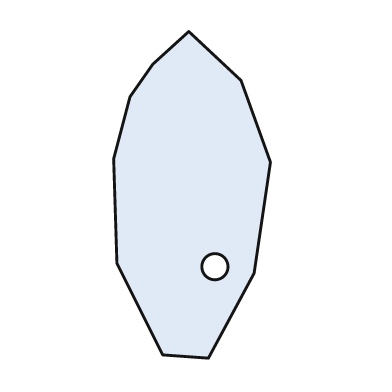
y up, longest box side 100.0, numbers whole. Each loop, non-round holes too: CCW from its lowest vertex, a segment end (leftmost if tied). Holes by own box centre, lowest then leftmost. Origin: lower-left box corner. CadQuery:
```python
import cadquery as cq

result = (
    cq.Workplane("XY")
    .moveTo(29.0, 0.0)
    .lineTo(43.0, 26.0)
    .lineTo(48.0, 60.0)
    .lineTo(39.0, 85.0)
    .lineTo(23.0, 100.0)
    .lineTo(12.0, 90.0)
    .lineTo(5.0, 80.0)
    .lineTo(0.0, 61.0)
    .lineTo(1.0, 29.0)
    .lineTo(15.0, 1.0)
    .close()
    .moveTo(31.0, 28.0)
    .circle(4.0)
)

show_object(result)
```